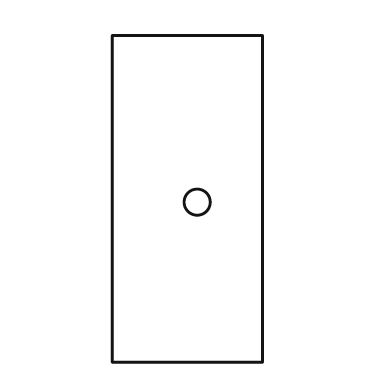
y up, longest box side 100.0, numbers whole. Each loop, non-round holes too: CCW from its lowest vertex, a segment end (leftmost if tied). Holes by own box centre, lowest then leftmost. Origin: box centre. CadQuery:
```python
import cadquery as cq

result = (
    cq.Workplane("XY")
    .moveTo(-23.0, -50.0)
    .lineTo(23.0, -50.0)
    .lineTo(23.0, 50.0)
    .lineTo(-23.0, 50.0)
    .close()
    .moveTo(3.0, -1.0)
    .circle(4.0)
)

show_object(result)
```